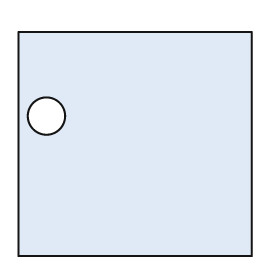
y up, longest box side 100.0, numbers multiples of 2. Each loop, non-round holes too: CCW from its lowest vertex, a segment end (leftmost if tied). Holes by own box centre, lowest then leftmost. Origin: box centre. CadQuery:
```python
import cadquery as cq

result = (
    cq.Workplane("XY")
    .moveTo(-50.0, -48.0)
    .lineTo(50.0, -48.0)
    .lineTo(50.0, 48.0)
    .lineTo(-50.0, 48.0)
    .close()
    .moveTo(-38.0, 12.0)
    .circle(8.0)
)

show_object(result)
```